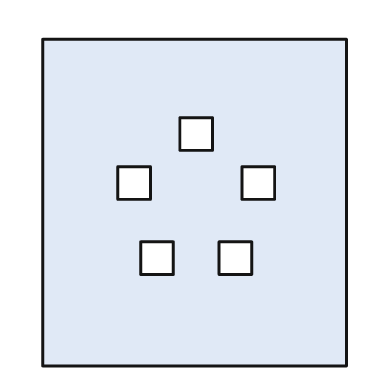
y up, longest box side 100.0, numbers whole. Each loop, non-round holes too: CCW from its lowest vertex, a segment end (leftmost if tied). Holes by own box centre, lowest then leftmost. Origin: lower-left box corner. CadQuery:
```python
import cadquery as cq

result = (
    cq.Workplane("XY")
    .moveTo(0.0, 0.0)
    .lineTo(93.0, 0.0)
    .lineTo(93.0, 100.0)
    .lineTo(0.0, 100.0)
    .close()
    .moveTo(30.0, 28.0)
    .lineTo(40.0, 28.0)
    .lineTo(40.0, 38.0)
    .lineTo(30.0, 38.0)
    .close()
    .moveTo(54.0, 28.0)
    .lineTo(64.0, 28.0)
    .lineTo(64.0, 38.0)
    .lineTo(54.0, 38.0)
    .close()
    .moveTo(23.0, 51.0)
    .lineTo(33.0, 51.0)
    .lineTo(33.0, 61.0)
    .lineTo(23.0, 61.0)
    .close()
    .moveTo(61.0, 51.0)
    .lineTo(71.0, 51.0)
    .lineTo(71.0, 61.0)
    .lineTo(61.0, 61.0)
    .close()
    .moveTo(42.0, 66.0)
    .lineTo(52.0, 66.0)
    .lineTo(52.0, 76.0)
    .lineTo(42.0, 76.0)
    .close()
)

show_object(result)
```